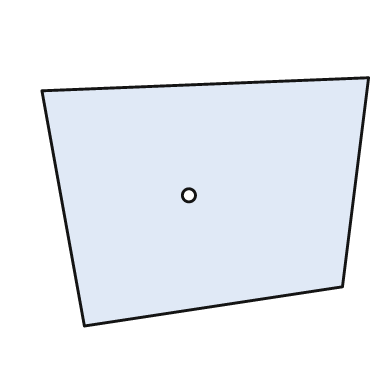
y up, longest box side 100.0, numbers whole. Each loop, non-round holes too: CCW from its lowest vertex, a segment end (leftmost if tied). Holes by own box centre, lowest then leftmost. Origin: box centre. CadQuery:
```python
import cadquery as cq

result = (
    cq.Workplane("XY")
    .moveTo(-37.0, -38.0)
    .lineTo(42.0, -26.0)
    .lineTo(50.0, 38.0)
    .lineTo(-50.0, 34.0)
    .close()
    .moveTo(-5.0, 2.0)
    .circle(2.0)
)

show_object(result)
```